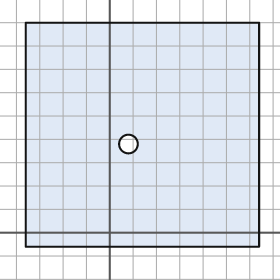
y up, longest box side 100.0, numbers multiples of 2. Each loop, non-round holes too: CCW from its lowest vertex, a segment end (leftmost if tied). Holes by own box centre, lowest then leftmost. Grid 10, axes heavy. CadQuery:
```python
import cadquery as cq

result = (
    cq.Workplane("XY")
    .moveTo(-36.0, -6.0)
    .lineTo(64.0, -6.0)
    .lineTo(64.0, 90.0)
    .lineTo(-36.0, 90.0)
    .close()
    .moveTo(8.0, 38.0)
    .circle(4.0)
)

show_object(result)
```